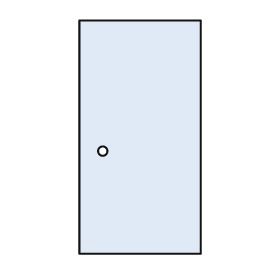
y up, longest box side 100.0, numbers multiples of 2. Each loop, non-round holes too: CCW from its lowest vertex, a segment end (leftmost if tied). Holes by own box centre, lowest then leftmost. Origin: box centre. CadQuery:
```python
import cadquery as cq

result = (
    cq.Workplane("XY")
    .moveTo(-26.0, -50.0)
    .lineTo(26.0, -50.0)
    .lineTo(26.0, 50.0)
    .lineTo(-26.0, 50.0)
    .close()
    .moveTo(-16.0, -6.0)
    .circle(2.0)
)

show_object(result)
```